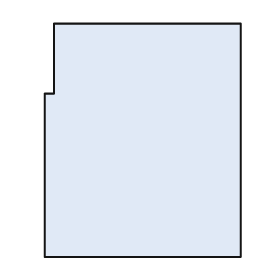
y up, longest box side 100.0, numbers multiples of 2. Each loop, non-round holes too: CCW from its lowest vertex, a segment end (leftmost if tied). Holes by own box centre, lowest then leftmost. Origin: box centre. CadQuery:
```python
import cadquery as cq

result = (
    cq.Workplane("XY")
    .moveTo(-42.0, -50.0)
    .lineTo(42.0, -50.0)
    .lineTo(42.0, 50.0)
    .lineTo(-38.0, 50.0)
    .lineTo(-38.0, 20.0)
    .lineTo(-42.0, 20.0)
    .close()
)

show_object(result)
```